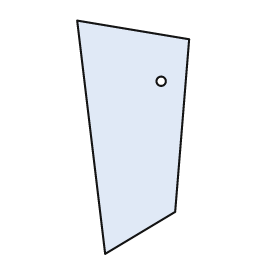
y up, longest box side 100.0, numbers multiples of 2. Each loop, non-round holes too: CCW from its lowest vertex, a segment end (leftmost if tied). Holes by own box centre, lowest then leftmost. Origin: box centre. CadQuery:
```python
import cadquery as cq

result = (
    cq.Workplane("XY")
    .moveTo(-12.0, -50.0)
    .lineTo(18.0, -32.0)
    .lineTo(24.0, 42.0)
    .lineTo(-24.0, 50.0)
    .close()
    .moveTo(12.0, 24.0)
    .circle(2.0)
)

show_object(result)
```